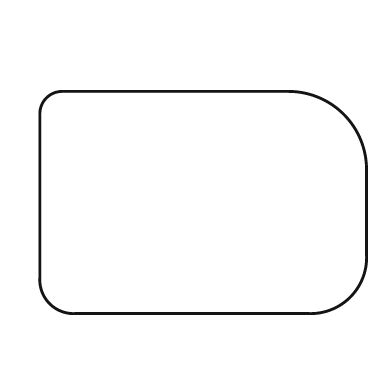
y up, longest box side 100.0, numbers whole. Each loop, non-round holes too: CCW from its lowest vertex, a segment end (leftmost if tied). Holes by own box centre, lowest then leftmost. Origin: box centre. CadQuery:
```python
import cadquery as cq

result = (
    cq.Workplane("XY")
    .moveTo(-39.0, -34.0)
    .lineTo(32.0, -34.0)
    .threePointArc((45.0, -29.0), (50.0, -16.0))
    .lineTo(50.0, 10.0)
    .threePointArc((43.0, 27.0), (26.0, 34.0))
    .lineTo(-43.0, 34.0)
    .threePointArc((-48.0, 32.0), (-50.0, 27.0))
    .lineTo(-50.0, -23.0)
    .threePointArc((-47.0, -31.0), (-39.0, -34.0))
    .close()
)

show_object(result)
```